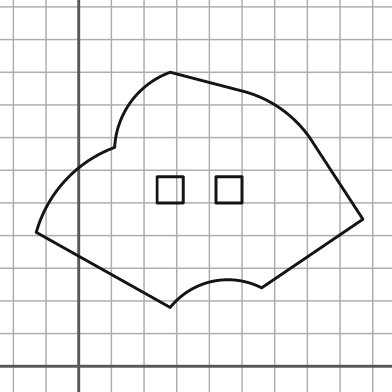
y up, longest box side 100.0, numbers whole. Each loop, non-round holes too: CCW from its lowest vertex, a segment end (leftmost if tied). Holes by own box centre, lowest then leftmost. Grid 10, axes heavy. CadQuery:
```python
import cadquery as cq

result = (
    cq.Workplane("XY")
    .moveTo(28.0, 18.0)
    .threePointArc((41.0, 26.0), (56.0, 24.0))
    .lineTo(87.0, 45.0)
    .lineTo(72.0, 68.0)
    .threePointArc((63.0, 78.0), (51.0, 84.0))
    .lineTo(28.0, 90.0)
    .threePointArc((16.0, 81.0), (11.0, 67.0))
    .threePointArc((-4.0, 57.0), (-13.0, 41.0))
    .close()
    .moveTo(24.0, 50.0)
    .lineTo(32.0, 50.0)
    .lineTo(32.0, 58.0)
    .lineTo(24.0, 58.0)
    .close()
    .moveTo(42.0, 50.0)
    .lineTo(50.0, 50.0)
    .lineTo(50.0, 58.0)
    .lineTo(42.0, 58.0)
    .close()
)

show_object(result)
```